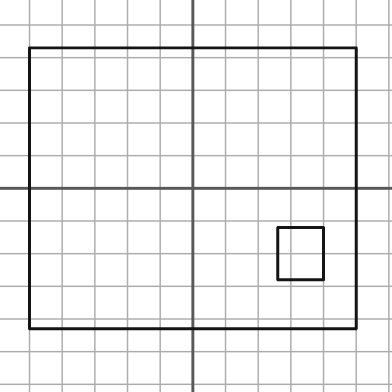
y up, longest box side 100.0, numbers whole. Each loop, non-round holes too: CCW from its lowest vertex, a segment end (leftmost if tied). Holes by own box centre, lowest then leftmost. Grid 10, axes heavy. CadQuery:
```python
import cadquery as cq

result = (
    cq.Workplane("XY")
    .moveTo(-50.0, -43.0)
    .lineTo(50.0, -43.0)
    .lineTo(50.0, 43.0)
    .lineTo(-50.0, 43.0)
    .close()
    .moveTo(26.0, -28.0)
    .lineTo(40.0, -28.0)
    .lineTo(40.0, -12.0)
    .lineTo(26.0, -12.0)
    .close()
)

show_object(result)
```